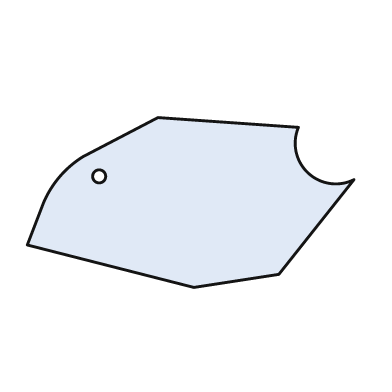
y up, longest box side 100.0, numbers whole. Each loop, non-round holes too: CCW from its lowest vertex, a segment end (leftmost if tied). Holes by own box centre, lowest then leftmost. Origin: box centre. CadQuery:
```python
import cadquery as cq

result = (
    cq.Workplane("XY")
    .moveTo(1.0, -26.0)
    .lineTo(27.0, -22.0)
    .lineTo(50.0, 7.0)
    .threePointArc((36.0, 9.0), (33.0, 23.0))
    .lineTo(-10.0, 26.0)
    .lineTo(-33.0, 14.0)
    .threePointArc((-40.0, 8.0), (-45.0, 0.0))
    .lineTo(-50.0, -13.0)
    .close()
    .moveTo(-28.0, 8.0)
    .circle(2.0)
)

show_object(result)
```